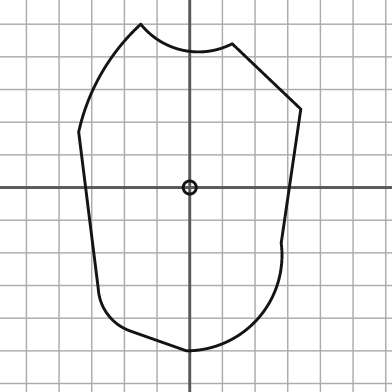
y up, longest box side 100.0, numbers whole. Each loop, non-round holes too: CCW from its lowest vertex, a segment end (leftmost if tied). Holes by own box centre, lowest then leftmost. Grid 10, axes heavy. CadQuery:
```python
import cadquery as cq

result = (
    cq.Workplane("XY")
    .moveTo(-1.0, -50.0)
    .threePointArc((21.0, -40.0), (28.0, -17.0))
    .lineTo(34.0, 24.0)
    .lineTo(13.0, 44.0)
    .threePointArc((-2.0, 42.0), (-15.0, 50.0))
    .threePointArc((-27.0, 35.0), (-34.0, 17.0))
    .lineTo(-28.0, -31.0)
    .threePointArc((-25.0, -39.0), (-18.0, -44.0))
    .close()
    .moveTo(0.0, 0.0)
    .circle(2.0)
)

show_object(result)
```